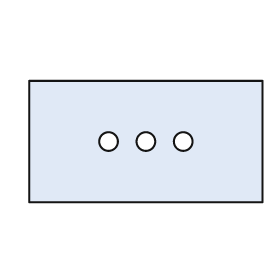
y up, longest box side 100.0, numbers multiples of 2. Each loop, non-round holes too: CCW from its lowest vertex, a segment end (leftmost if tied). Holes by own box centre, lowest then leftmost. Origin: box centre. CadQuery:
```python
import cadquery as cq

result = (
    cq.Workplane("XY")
    .moveTo(-50.0, -26.0)
    .lineTo(50.0, -26.0)
    .lineTo(50.0, 26.0)
    .lineTo(-50.0, 26.0)
    .close()
    .moveTo(-16.0, 0.0)
    .circle(4.0)
    .moveTo(0.0, 0.0)
    .circle(4.0)
    .moveTo(16.0, 0.0)
    .circle(4.0)
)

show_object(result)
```